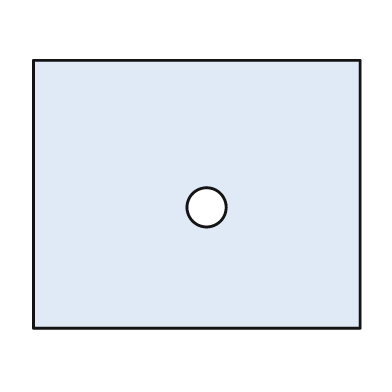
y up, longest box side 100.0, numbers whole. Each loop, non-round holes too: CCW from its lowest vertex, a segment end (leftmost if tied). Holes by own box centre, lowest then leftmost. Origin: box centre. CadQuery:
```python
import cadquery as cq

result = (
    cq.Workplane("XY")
    .moveTo(-50.0, -41.0)
    .lineTo(50.0, -41.0)
    .lineTo(50.0, 41.0)
    .lineTo(-50.0, 41.0)
    .close()
    .moveTo(3.0, -4.0)
    .circle(6.0)
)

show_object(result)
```